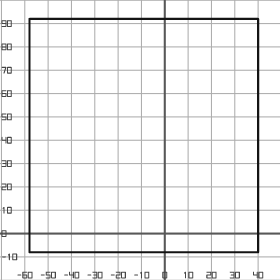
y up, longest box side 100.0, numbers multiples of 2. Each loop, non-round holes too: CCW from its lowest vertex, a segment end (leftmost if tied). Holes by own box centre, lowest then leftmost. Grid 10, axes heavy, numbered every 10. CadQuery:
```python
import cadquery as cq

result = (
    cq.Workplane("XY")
    .moveTo(-58.0, -8.0)
    .lineTo(40.0, -8.0)
    .lineTo(40.0, 92.0)
    .lineTo(-58.0, 92.0)
    .close()
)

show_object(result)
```